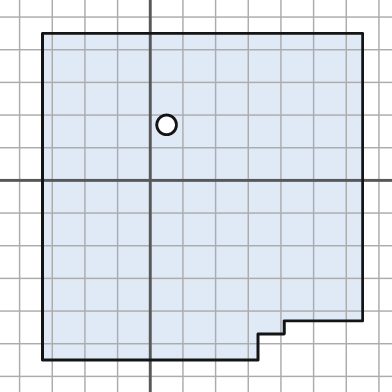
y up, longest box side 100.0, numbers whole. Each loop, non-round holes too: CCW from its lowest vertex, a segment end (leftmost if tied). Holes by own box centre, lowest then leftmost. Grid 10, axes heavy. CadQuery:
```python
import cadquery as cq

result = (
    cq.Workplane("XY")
    .moveTo(-33.0, -55.0)
    .lineTo(33.0, -55.0)
    .lineTo(33.0, -47.0)
    .lineTo(41.0, -47.0)
    .lineTo(41.0, -43.0)
    .lineTo(65.0, -43.0)
    .lineTo(65.0, 45.0)
    .lineTo(-33.0, 45.0)
    .close()
    .moveTo(5.0, 17.0)
    .circle(3.0)
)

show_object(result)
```